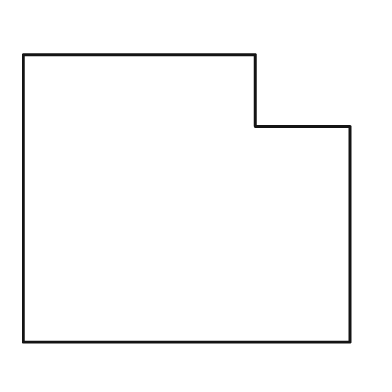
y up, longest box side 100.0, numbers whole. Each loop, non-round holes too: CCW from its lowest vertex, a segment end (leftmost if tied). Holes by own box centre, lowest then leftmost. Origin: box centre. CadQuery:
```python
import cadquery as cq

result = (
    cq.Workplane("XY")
    .moveTo(-50.0, -44.0)
    .lineTo(50.0, -44.0)
    .lineTo(50.0, 22.0)
    .lineTo(21.0, 22.0)
    .lineTo(21.0, 44.0)
    .lineTo(-50.0, 44.0)
    .close()
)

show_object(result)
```